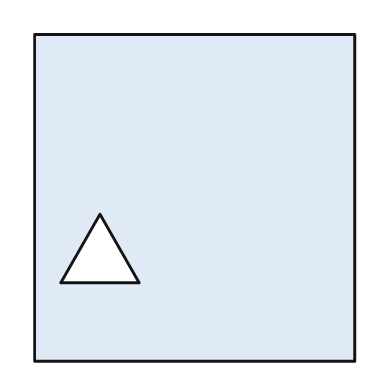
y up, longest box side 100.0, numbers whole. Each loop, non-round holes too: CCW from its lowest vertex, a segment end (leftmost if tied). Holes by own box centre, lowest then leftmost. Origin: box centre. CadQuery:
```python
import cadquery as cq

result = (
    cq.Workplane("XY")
    .moveTo(-49.0, -50.0)
    .lineTo(49.0, -50.0)
    .lineTo(49.0, 50.0)
    .lineTo(-49.0, 50.0)
    .close()
    .moveTo(-41.0, -26.0)
    .lineTo(-17.0, -26.0)
    .lineTo(-29.0, -5.0)
    .close()
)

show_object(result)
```